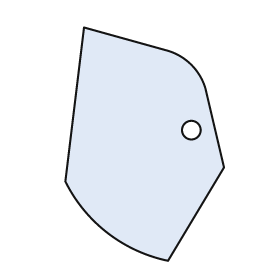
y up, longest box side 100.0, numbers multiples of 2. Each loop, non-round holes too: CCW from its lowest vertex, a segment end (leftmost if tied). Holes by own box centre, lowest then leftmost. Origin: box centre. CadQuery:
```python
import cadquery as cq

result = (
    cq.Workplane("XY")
    .moveTo(10.0, -50.0)
    .lineTo(34.0, -10.0)
    .lineTo(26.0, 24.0)
    .threePointArc((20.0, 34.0), (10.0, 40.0))
    .lineTo(-26.0, 50.0)
    .lineTo(-34.0, -16.0)
    .threePointArc((-16.0, -38.0), (10.0, -50.0))
    .close()
    .moveTo(20.0, 6.0)
    .circle(4.0)
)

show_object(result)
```